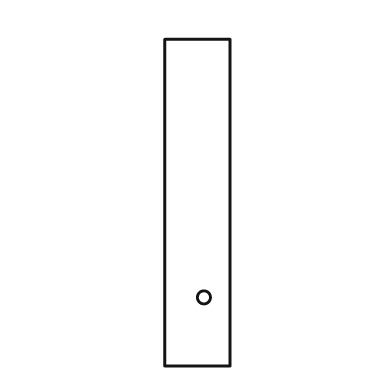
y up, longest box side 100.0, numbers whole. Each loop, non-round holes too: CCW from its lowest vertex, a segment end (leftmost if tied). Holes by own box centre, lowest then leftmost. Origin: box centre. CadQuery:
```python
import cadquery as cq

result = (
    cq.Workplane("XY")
    .moveTo(-10.0, -50.0)
    .lineTo(10.0, -50.0)
    .lineTo(10.0, 50.0)
    .lineTo(-10.0, 50.0)
    .close()
    .moveTo(2.0, -29.0)
    .circle(2.0)
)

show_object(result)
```